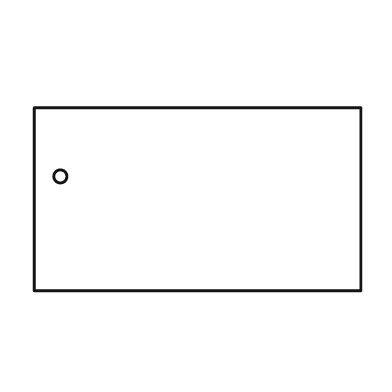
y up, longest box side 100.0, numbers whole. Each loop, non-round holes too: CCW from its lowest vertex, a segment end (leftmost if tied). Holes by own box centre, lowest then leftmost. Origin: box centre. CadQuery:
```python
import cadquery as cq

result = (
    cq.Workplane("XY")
    .moveTo(-50.0, -28.0)
    .lineTo(50.0, -28.0)
    .lineTo(50.0, 28.0)
    .lineTo(-50.0, 28.0)
    .close()
    .moveTo(-42.0, 7.0)
    .circle(2.0)
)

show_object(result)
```